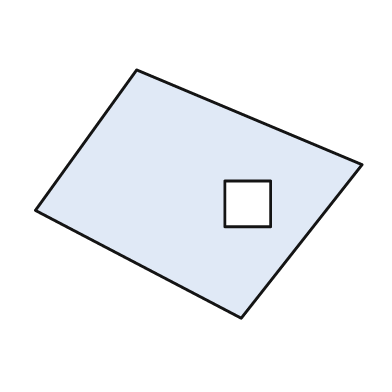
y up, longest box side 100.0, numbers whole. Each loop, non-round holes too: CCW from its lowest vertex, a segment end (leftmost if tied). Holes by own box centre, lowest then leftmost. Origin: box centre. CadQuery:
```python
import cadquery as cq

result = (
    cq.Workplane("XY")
    .moveTo(13.0, -38.0)
    .lineTo(50.0, 9.0)
    .lineTo(-19.0, 38.0)
    .lineTo(-50.0, -5.0)
    .close()
    .moveTo(8.0, -10.0)
    .lineTo(22.0, -10.0)
    .lineTo(22.0, 4.0)
    .lineTo(8.0, 4.0)
    .close()
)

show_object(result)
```